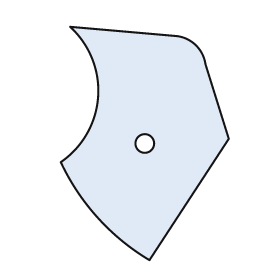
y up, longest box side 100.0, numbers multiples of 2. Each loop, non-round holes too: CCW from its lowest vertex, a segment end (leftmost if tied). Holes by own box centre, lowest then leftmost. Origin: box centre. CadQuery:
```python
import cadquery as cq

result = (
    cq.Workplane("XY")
    .moveTo(2.0, -50.0)
    .lineTo(36.0, 2.0)
    .lineTo(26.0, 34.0)
    .threePointArc((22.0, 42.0), (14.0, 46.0))
    .lineTo(-32.0, 50.0)
    .threePointArc((-20.0, 20.0), (-36.0, -8.0))
    .threePointArc((-20.0, -32.0), (2.0, -50.0))
    .close()
    .moveTo(0.0, 0.0)
    .circle(4.0)
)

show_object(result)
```